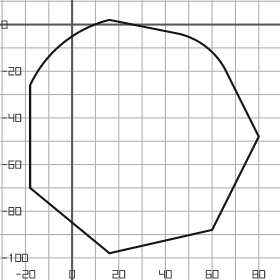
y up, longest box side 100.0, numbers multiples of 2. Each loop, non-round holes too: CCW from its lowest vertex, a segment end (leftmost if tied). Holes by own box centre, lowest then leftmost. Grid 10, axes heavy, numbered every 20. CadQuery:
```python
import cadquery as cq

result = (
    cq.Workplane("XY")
    .moveTo(16.0, -98.0)
    .lineTo(60.0, -88.0)
    .lineTo(80.0, -48.0)
    .lineTo(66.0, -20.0)
    .threePointArc((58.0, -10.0), (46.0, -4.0))
    .lineTo(16.0, 2.0)
    .threePointArc((-4.0, -8.0), (-18.0, -26.0))
    .lineTo(-18.0, -70.0)
    .close()
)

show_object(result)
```